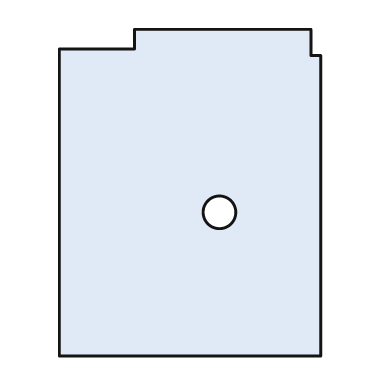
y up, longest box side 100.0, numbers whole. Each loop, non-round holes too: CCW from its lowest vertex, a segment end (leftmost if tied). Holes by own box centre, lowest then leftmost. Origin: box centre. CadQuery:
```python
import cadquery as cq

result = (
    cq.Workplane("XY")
    .moveTo(-40.0, -50.0)
    .lineTo(40.0, -50.0)
    .lineTo(40.0, 42.0)
    .lineTo(37.0, 42.0)
    .lineTo(37.0, 50.0)
    .lineTo(-17.0, 50.0)
    .lineTo(-17.0, 44.0)
    .lineTo(-40.0, 44.0)
    .close()
    .moveTo(9.0, -6.0)
    .circle(5.0)
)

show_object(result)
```